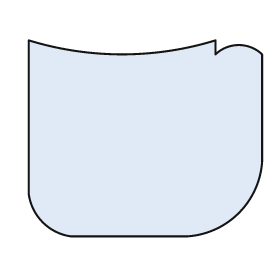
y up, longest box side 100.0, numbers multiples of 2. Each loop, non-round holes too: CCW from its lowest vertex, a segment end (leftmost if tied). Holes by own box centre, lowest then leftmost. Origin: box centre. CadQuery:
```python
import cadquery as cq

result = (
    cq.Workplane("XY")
    .moveTo(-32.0, -42.0)
    .lineTo(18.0, -42.0)
    .threePointArc((40.0, -32.0), (50.0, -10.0))
    .lineTo(50.0, 36.0)
    .threePointArc((40.0, 40.0), (30.0, 36.0))
    .lineTo(30.0, 42.0)
    .threePointArc((-10.0, 36.0), (-50.0, 42.0))
    .lineTo(-50.0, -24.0)
    .threePointArc((-44.0, -36.0), (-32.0, -42.0))
    .close()
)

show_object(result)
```